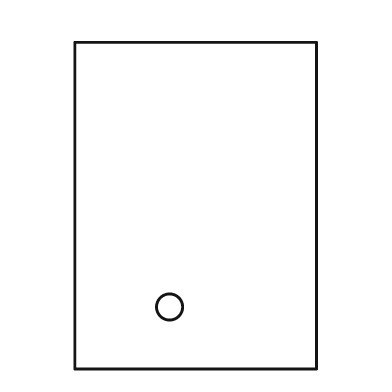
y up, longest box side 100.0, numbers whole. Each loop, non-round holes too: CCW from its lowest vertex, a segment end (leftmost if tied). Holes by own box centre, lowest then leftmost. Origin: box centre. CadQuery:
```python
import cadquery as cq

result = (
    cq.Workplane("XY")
    .moveTo(-37.0, -50.0)
    .lineTo(37.0, -50.0)
    .lineTo(37.0, 50.0)
    .lineTo(-37.0, 50.0)
    .close()
    .moveTo(-8.0, -31.0)
    .circle(4.0)
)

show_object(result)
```